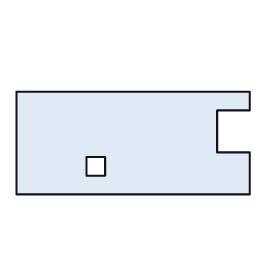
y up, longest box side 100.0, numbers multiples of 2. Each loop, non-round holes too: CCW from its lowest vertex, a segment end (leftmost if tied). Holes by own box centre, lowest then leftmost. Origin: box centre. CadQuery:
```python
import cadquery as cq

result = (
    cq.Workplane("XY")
    .moveTo(-50.0, -22.0)
    .lineTo(50.0, -22.0)
    .lineTo(50.0, -4.0)
    .lineTo(36.0, -4.0)
    .lineTo(36.0, 14.0)
    .lineTo(50.0, 14.0)
    .lineTo(50.0, 22.0)
    .lineTo(-50.0, 22.0)
    .close()
    .moveTo(-20.0, -14.0)
    .lineTo(-12.0, -14.0)
    .lineTo(-12.0, -6.0)
    .lineTo(-20.0, -6.0)
    .close()
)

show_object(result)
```